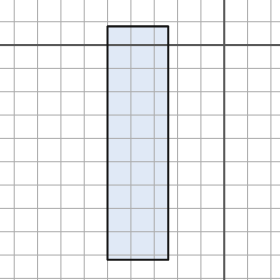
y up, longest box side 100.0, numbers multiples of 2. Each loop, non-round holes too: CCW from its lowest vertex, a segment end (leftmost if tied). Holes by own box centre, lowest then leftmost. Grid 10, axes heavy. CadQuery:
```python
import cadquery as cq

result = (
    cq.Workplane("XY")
    .moveTo(-50.0, -92.0)
    .lineTo(-24.0, -92.0)
    .lineTo(-24.0, 8.0)
    .lineTo(-50.0, 8.0)
    .close()
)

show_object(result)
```